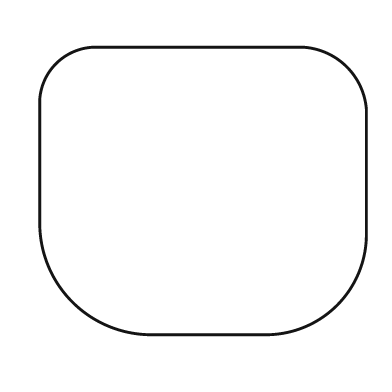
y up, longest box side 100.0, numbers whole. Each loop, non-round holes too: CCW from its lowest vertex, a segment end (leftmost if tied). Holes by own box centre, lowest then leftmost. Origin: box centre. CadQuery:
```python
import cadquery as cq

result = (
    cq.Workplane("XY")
    .moveTo(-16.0, -44.0)
    .lineTo(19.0, -44.0)
    .threePointArc((41.0, -35.0), (50.0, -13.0))
    .lineTo(50.0, 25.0)
    .threePointArc((44.0, 38.0), (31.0, 44.0))
    .lineTo(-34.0, 44.0)
    .threePointArc((-45.0, 39.0), (-50.0, 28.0))
    .lineTo(-50.0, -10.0)
    .threePointArc((-40.0, -34.0), (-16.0, -44.0))
    .close()
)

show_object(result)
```